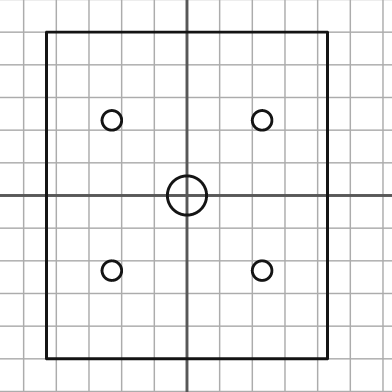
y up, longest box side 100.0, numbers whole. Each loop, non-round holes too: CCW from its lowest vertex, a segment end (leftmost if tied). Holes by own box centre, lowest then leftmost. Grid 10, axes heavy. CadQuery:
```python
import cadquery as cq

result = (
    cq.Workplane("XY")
    .moveTo(-43.0, -50.0)
    .lineTo(43.0, -50.0)
    .lineTo(43.0, 50.0)
    .lineTo(-43.0, 50.0)
    .close()
    .moveTo(-23.0, -23.0)
    .circle(3.0)
    .moveTo(23.0, -23.0)
    .circle(3.0)
    .moveTo(0.0, 0.0)
    .circle(6.0)
    .moveTo(-23.0, 23.0)
    .circle(3.0)
    .moveTo(23.0, 23.0)
    .circle(3.0)
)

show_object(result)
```